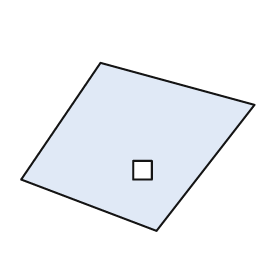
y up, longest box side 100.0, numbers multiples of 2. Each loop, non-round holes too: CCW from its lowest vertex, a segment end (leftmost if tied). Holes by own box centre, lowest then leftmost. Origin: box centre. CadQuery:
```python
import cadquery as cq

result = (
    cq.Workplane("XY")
    .moveTo(8.0, -36.0)
    .lineTo(50.0, 18.0)
    .lineTo(-16.0, 36.0)
    .lineTo(-50.0, -14.0)
    .close()
    .moveTo(-2.0, -14.0)
    .lineTo(6.0, -14.0)
    .lineTo(6.0, -6.0)
    .lineTo(-2.0, -6.0)
    .close()
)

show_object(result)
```